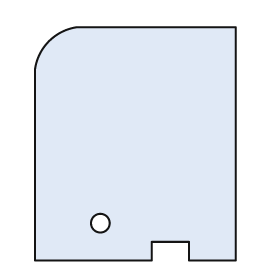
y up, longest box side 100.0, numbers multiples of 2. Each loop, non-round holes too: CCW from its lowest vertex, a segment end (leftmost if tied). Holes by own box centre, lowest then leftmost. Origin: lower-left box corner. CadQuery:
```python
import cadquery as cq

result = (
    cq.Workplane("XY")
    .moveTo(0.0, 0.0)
    .lineTo(50.0, 0.0)
    .lineTo(50.0, 8.0)
    .lineTo(66.0, 8.0)
    .lineTo(66.0, 0.0)
    .lineTo(86.0, 0.0)
    .lineTo(86.0, 100.0)
    .lineTo(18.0, 100.0)
    .threePointArc((6.0, 94.0), (0.0, 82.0))
    .close()
    .moveTo(28.0, 16.0)
    .circle(4.0)
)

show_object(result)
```